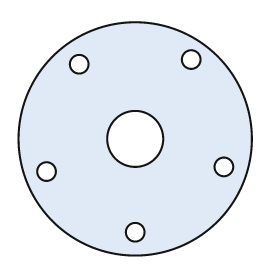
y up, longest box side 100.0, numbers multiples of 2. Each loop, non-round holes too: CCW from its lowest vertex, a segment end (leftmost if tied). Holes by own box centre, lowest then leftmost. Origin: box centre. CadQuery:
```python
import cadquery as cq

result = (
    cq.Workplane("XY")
    .moveTo(0.0, 0.0)
    .circle(50.0)
    .moveTo(0.0, -40.0)
    .circle(4.0)
    .moveTo(-38.0, -14.0)
    .circle(4.0)
    .moveTo(38.0, -12.0)
    .circle(4.0)
    .moveTo(0.0, 0.0)
    .circle(12.0)
    .moveTo(-24.0, 32.0)
    .circle(4.0)
    .moveTo(24.0, 34.0)
    .circle(4.0)
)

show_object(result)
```